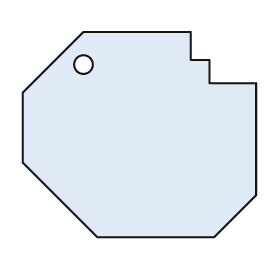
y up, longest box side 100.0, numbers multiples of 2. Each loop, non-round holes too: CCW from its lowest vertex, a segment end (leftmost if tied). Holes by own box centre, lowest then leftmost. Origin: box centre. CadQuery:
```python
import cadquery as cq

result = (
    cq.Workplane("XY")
    .moveTo(-18.0, -44.0)
    .lineTo(32.0, -44.0)
    .lineTo(50.0, -26.0)
    .lineTo(50.0, 22.0)
    .lineTo(30.0, 22.0)
    .lineTo(30.0, 32.0)
    .lineTo(22.0, 32.0)
    .lineTo(22.0, 44.0)
    .lineTo(-24.0, 44.0)
    .lineTo(-50.0, 18.0)
    .lineTo(-50.0, -12.0)
    .close()
    .moveTo(-24.0, 30.0)
    .circle(4.0)
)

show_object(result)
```